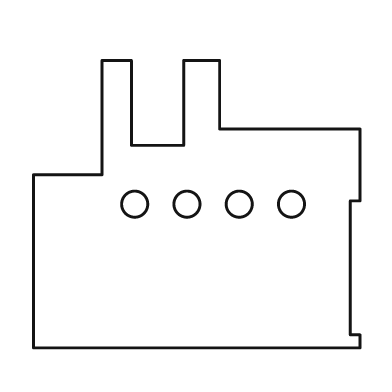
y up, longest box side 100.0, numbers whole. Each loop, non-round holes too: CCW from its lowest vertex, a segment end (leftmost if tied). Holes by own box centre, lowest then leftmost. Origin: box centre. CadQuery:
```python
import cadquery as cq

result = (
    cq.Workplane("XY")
    .moveTo(-50.0, -44.0)
    .lineTo(50.0, -44.0)
    .lineTo(50.0, -40.0)
    .lineTo(47.0, -40.0)
    .lineTo(47.0, 1.0)
    .lineTo(50.0, 1.0)
    .lineTo(50.0, 23.0)
    .lineTo(7.0, 23.0)
    .lineTo(7.0, 44.0)
    .lineTo(-4.0, 44.0)
    .lineTo(-4.0, 18.0)
    .lineTo(-20.0, 18.0)
    .lineTo(-20.0, 44.0)
    .lineTo(-29.0, 44.0)
    .lineTo(-29.0, 9.0)
    .lineTo(-50.0, 9.0)
    .close()
    .moveTo(-19.0, 0.0)
    .circle(4.0)
    .moveTo(-3.0, 0.0)
    .circle(4.0)
    .moveTo(13.0, 0.0)
    .circle(4.0)
    .moveTo(29.0, 0.0)
    .circle(4.0)
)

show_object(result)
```